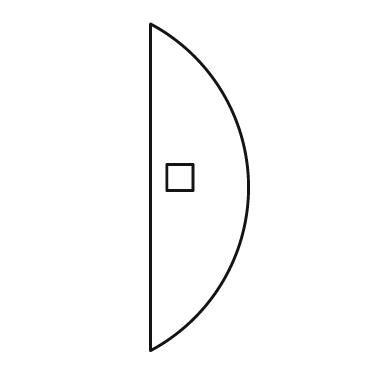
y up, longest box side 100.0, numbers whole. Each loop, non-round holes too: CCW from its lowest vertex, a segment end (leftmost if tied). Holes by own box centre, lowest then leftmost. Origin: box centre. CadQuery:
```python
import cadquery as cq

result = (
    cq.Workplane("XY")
    .moveTo(-15.0, -50.0)
    .threePointArc((15.0, 0.0), (-15.0, 50.0))
    .close()
    .moveTo(-10.0, -1.0)
    .lineTo(-2.0, -1.0)
    .lineTo(-2.0, 7.0)
    .lineTo(-10.0, 7.0)
    .close()
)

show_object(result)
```